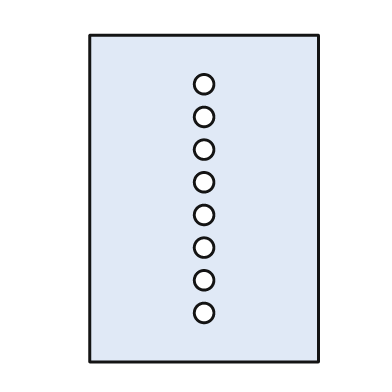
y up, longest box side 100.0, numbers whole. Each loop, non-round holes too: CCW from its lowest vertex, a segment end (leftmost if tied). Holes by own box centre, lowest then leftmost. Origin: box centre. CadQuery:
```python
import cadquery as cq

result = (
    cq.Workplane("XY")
    .moveTo(-35.0, -50.0)
    .lineTo(35.0, -50.0)
    .lineTo(35.0, 50.0)
    .lineTo(-35.0, 50.0)
    .close()
    .moveTo(0.0, -35.0)
    .circle(3.0)
    .moveTo(0.0, -25.0)
    .circle(3.0)
    .moveTo(0.0, -15.0)
    .circle(3.0)
    .moveTo(0.0, -5.0)
    .circle(3.0)
    .moveTo(0.0, 5.0)
    .circle(3.0)
    .moveTo(0.0, 15.0)
    .circle(3.0)
    .moveTo(0.0, 25.0)
    .circle(3.0)
    .moveTo(0.0, 35.0)
    .circle(3.0)
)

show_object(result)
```